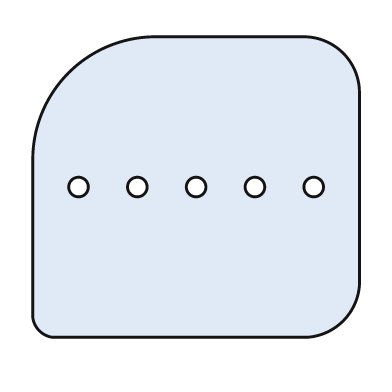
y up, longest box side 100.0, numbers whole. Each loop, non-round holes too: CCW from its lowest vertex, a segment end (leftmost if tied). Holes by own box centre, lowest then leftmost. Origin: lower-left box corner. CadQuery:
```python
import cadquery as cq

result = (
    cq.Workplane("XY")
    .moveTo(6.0, 0.0)
    .lineTo(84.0, 0.0)
    .threePointArc((95.0, 5.0), (100.0, 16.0))
    .lineTo(100.0, 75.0)
    .threePointArc((95.0, 87.0), (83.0, 92.0))
    .lineTo(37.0, 92.0)
    .threePointArc((11.0, 81.0), (0.0, 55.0))
    .lineTo(0.0, 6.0)
    .threePointArc((2.0, 2.0), (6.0, 0.0))
    .close()
    .moveTo(14.0, 46.0)
    .circle(3.0)
    .moveTo(32.0, 46.0)
    .circle(3.0)
    .moveTo(50.0, 46.0)
    .circle(3.0)
    .moveTo(68.0, 46.0)
    .circle(3.0)
    .moveTo(86.0, 46.0)
    .circle(3.0)
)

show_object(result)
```